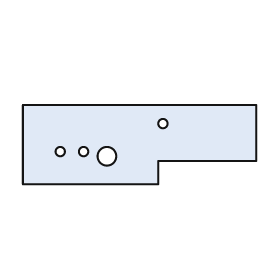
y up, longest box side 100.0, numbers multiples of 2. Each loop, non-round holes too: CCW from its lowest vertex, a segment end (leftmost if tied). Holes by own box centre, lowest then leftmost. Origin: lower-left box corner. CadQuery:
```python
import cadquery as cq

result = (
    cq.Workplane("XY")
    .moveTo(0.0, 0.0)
    .lineTo(58.0, 0.0)
    .lineTo(58.0, 10.0)
    .lineTo(100.0, 10.0)
    .lineTo(100.0, 34.0)
    .lineTo(0.0, 34.0)
    .close()
    .moveTo(36.0, 12.0)
    .circle(4.0)
    .moveTo(16.0, 14.0)
    .circle(2.0)
    .moveTo(26.0, 14.0)
    .circle(2.0)
    .moveTo(60.0, 26.0)
    .circle(2.0)
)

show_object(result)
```